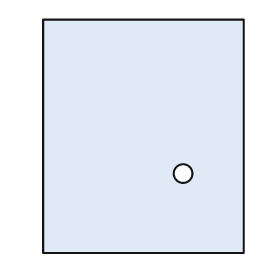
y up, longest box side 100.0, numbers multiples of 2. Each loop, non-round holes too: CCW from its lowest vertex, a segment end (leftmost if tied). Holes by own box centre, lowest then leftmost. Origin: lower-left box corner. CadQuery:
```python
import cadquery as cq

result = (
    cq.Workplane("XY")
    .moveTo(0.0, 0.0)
    .lineTo(86.0, 0.0)
    .lineTo(86.0, 100.0)
    .lineTo(0.0, 100.0)
    .close()
    .moveTo(60.0, 34.0)
    .circle(4.0)
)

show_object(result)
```